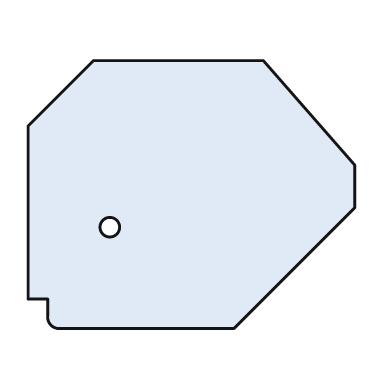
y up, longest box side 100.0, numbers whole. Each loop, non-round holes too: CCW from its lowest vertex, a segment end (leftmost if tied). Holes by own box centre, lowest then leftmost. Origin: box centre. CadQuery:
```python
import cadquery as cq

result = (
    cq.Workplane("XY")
    .moveTo(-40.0, -41.0)
    .lineTo(13.0, -41.0)
    .lineTo(50.0, -4.0)
    .lineTo(50.0, 9.0)
    .lineTo(22.0, 41.0)
    .lineTo(-30.0, 41.0)
    .lineTo(-50.0, 21.0)
    .lineTo(-50.0, -32.0)
    .lineTo(-44.0, -32.0)
    .lineTo(-44.0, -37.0)
    .threePointArc((-43.0, -40.0), (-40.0, -41.0))
    .close()
    .moveTo(-25.0, -10.0)
    .circle(3.0)
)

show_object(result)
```